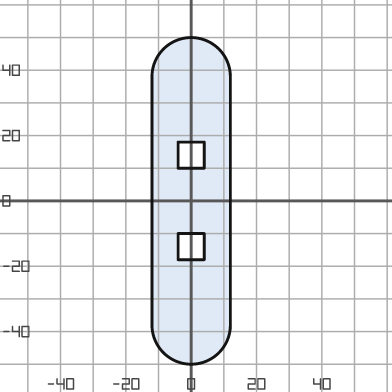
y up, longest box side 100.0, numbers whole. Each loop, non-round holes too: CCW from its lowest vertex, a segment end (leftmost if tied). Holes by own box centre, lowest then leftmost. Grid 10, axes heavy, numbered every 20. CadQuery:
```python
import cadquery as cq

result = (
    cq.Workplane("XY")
    .moveTo(-12.0, -38.0)
    .threePointArc((0.0, -50.0), (12.0, -38.0))
    .lineTo(12.0, 38.0)
    .threePointArc((0.0, 50.0), (-12.0, 38.0))
    .close()
    .moveTo(-4.0, -18.0)
    .lineTo(4.0, -18.0)
    .lineTo(4.0, -10.0)
    .lineTo(-4.0, -10.0)
    .close()
    .moveTo(-4.0, 10.0)
    .lineTo(4.0, 10.0)
    .lineTo(4.0, 18.0)
    .lineTo(-4.0, 18.0)
    .close()
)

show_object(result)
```